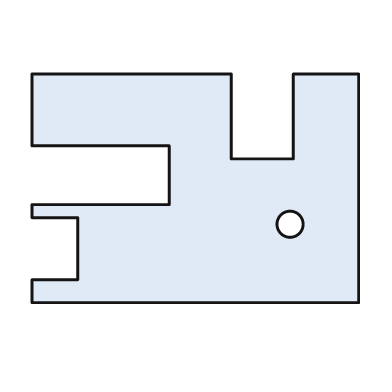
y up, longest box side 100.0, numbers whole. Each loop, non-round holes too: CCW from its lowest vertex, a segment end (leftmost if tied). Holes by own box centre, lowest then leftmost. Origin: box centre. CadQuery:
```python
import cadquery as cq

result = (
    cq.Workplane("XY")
    .moveTo(-50.0, -35.0)
    .lineTo(50.0, -35.0)
    .lineTo(50.0, 35.0)
    .lineTo(30.0, 35.0)
    .lineTo(30.0, 9.0)
    .lineTo(11.0, 9.0)
    .lineTo(11.0, 35.0)
    .lineTo(-50.0, 35.0)
    .lineTo(-50.0, 13.0)
    .lineTo(-8.0, 13.0)
    .lineTo(-8.0, -5.0)
    .lineTo(-50.0, -5.0)
    .lineTo(-50.0, -9.0)
    .lineTo(-36.0, -9.0)
    .lineTo(-36.0, -28.0)
    .lineTo(-50.0, -28.0)
    .close()
    .moveTo(29.0, -11.0)
    .circle(4.0)
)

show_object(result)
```